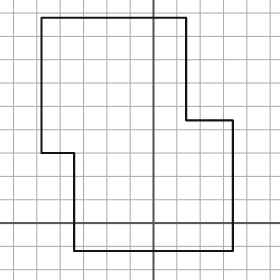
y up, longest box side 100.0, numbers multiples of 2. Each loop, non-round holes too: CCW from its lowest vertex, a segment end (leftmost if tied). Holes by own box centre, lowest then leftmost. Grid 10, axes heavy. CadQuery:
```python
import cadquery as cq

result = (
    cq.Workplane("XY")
    .moveTo(-34.0, -12.0)
    .lineTo(34.0, -12.0)
    .lineTo(34.0, 44.0)
    .lineTo(14.0, 44.0)
    .lineTo(14.0, 88.0)
    .lineTo(-48.0, 88.0)
    .lineTo(-48.0, 30.0)
    .lineTo(-34.0, 30.0)
    .close()
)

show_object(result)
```